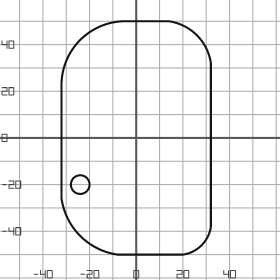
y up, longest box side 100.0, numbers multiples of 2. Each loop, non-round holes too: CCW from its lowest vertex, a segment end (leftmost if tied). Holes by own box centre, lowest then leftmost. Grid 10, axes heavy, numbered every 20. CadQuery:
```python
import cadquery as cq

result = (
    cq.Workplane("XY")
    .moveTo(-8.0, -50.0)
    .lineTo(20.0, -50.0)
    .threePointArc((28.0, -46.0), (32.0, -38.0))
    .lineTo(32.0, 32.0)
    .threePointArc((26.0, 44.0), (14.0, 50.0))
    .lineTo(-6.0, 50.0)
    .threePointArc((-24.0, 42.0), (-32.0, 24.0))
    .lineTo(-32.0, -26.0)
    .threePointArc((-24.0, -42.0), (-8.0, -50.0))
    .close()
    .moveTo(-24.0, -20.0)
    .circle(4.0)
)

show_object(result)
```